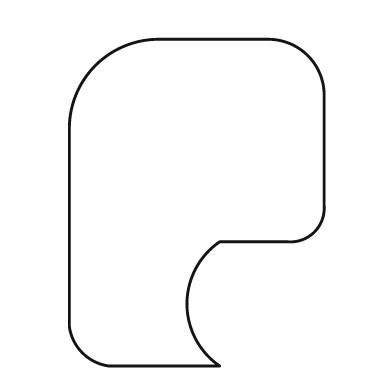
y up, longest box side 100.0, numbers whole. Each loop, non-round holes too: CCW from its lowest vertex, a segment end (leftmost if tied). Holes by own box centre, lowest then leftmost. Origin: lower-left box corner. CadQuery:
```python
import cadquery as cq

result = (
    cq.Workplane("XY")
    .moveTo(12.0, 0.0)
    .lineTo(46.0, 0.0)
    .threePointArc((36.0, 19.0), (46.0, 38.0))
    .lineTo(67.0, 38.0)
    .threePointArc((75.0, 41.0), (78.0, 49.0))
    .lineTo(78.0, 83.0)
    .threePointArc((73.0, 95.0), (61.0, 100.0))
    .lineTo(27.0, 100.0)
    .threePointArc((8.0, 92.0), (0.0, 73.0))
    .lineTo(0.0, 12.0)
    .threePointArc((4.0, 4.0), (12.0, 0.0))
    .close()
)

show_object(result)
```